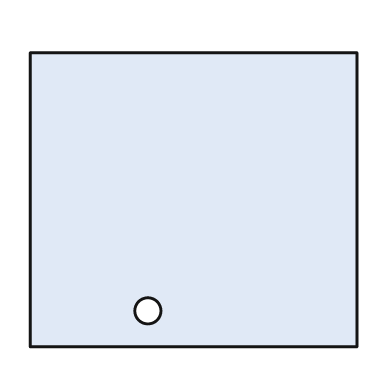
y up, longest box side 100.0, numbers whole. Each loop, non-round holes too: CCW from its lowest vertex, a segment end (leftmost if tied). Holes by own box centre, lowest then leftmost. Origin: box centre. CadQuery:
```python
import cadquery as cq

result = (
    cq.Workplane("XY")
    .moveTo(-50.0, -45.0)
    .lineTo(50.0, -45.0)
    .lineTo(50.0, 45.0)
    .lineTo(-50.0, 45.0)
    .close()
    .moveTo(-14.0, -34.0)
    .circle(4.0)
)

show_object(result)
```